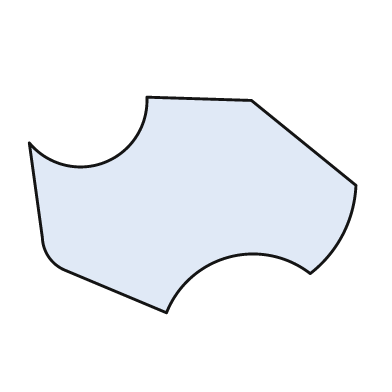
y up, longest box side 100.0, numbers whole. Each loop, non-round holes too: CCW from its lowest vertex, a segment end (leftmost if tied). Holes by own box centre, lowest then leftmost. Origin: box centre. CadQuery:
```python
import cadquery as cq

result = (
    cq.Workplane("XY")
    .moveTo(-8.0, -33.0)
    .threePointArc((11.0, -16.0), (36.0, -21.0))
    .threePointArc((46.0, -9.0), (50.0, 6.0))
    .lineTo(18.0, 32.0)
    .lineTo(-14.0, 33.0)
    .threePointArc((-27.0, 13.0), (-50.0, 19.0))
    .lineTo(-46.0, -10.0)
    .threePointArc((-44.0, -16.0), (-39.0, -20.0))
    .close()
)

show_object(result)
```